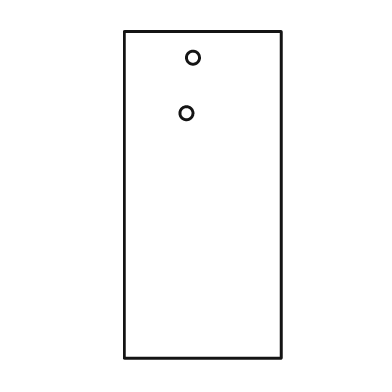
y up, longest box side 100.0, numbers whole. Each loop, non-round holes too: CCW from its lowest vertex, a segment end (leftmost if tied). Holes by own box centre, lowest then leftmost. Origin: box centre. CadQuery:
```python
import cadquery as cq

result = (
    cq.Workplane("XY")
    .moveTo(-24.0, -50.0)
    .lineTo(24.0, -50.0)
    .lineTo(24.0, 50.0)
    .lineTo(-24.0, 50.0)
    .close()
    .moveTo(-5.0, 25.0)
    .circle(2.0)
    .moveTo(-3.0, 42.0)
    .circle(2.0)
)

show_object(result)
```